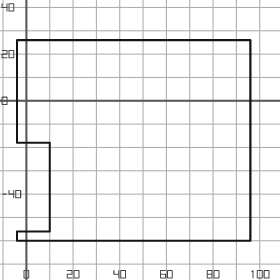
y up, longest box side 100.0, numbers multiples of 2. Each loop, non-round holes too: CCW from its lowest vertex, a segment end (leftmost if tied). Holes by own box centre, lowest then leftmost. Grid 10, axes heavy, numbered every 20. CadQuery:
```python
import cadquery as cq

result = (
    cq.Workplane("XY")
    .moveTo(-4.0, -60.0)
    .lineTo(96.0, -60.0)
    .lineTo(96.0, 26.0)
    .lineTo(-4.0, 26.0)
    .lineTo(-4.0, -18.0)
    .lineTo(10.0, -18.0)
    .lineTo(10.0, -56.0)
    .lineTo(-4.0, -56.0)
    .close()
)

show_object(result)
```